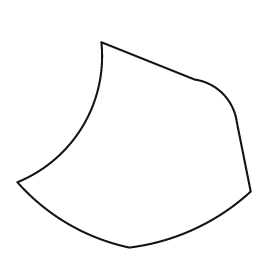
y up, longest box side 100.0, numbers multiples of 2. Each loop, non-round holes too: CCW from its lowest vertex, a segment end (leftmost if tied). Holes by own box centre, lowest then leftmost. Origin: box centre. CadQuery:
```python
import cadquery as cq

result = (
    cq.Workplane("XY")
    .moveTo(-2.0, -44.0)
    .threePointArc((26.0, -36.0), (50.0, -20.0))
    .lineTo(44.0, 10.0)
    .threePointArc((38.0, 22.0), (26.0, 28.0))
    .lineTo(-14.0, 44.0)
    .threePointArc((-22.0, 8.0), (-50.0, -16.0))
    .threePointArc((-28.0, -34.0), (-2.0, -44.0))
    .close()
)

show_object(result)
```